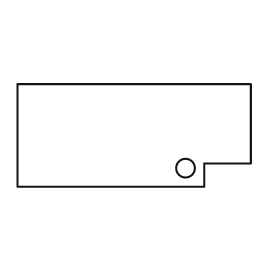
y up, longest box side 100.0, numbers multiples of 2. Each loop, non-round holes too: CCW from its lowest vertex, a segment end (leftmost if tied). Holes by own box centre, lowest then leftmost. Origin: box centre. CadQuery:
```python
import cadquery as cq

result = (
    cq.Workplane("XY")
    .moveTo(-50.0, -22.0)
    .lineTo(30.0, -22.0)
    .lineTo(30.0, -12.0)
    .lineTo(50.0, -12.0)
    .lineTo(50.0, 22.0)
    .lineTo(-50.0, 22.0)
    .close()
    .moveTo(22.0, -14.0)
    .circle(4.0)
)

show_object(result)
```